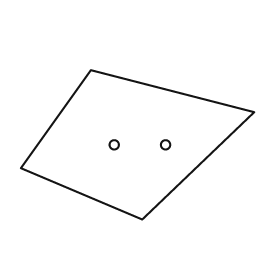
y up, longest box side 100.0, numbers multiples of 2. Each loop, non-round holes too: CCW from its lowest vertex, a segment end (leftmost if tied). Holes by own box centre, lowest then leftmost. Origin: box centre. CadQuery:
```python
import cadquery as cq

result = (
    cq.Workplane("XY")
    .moveTo(2.0, -32.0)
    .lineTo(50.0, 14.0)
    .lineTo(-20.0, 32.0)
    .lineTo(-50.0, -10.0)
    .close()
    .moveTo(-10.0, 0.0)
    .circle(2.0)
    .moveTo(12.0, 0.0)
    .circle(2.0)
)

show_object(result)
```